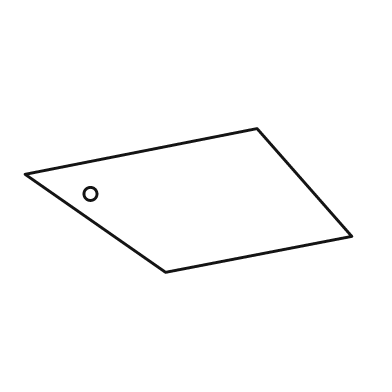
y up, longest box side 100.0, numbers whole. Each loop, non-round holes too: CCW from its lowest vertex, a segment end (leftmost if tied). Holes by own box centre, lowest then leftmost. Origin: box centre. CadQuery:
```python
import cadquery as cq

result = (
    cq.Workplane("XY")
    .moveTo(-7.0, -22.0)
    .lineTo(50.0, -11.0)
    .lineTo(21.0, 22.0)
    .lineTo(-50.0, 8.0)
    .close()
    .moveTo(-30.0, 2.0)
    .circle(2.0)
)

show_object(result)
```